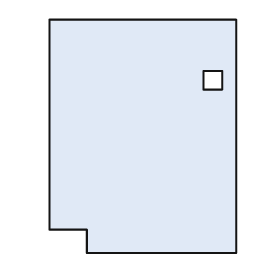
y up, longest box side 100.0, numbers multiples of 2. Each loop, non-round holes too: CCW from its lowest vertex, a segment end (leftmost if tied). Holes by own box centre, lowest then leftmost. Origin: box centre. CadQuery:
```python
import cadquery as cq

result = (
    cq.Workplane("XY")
    .moveTo(-24.0, -50.0)
    .lineTo(40.0, -50.0)
    .lineTo(40.0, 50.0)
    .lineTo(-40.0, 50.0)
    .lineTo(-40.0, -40.0)
    .lineTo(-24.0, -40.0)
    .close()
    .moveTo(26.0, 20.0)
    .lineTo(34.0, 20.0)
    .lineTo(34.0, 28.0)
    .lineTo(26.0, 28.0)
    .close()
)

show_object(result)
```